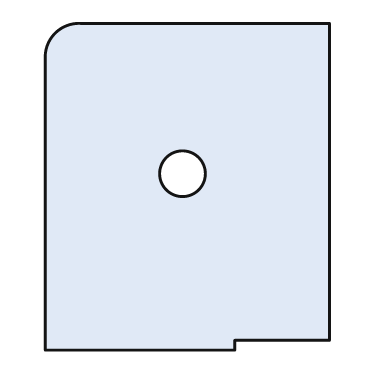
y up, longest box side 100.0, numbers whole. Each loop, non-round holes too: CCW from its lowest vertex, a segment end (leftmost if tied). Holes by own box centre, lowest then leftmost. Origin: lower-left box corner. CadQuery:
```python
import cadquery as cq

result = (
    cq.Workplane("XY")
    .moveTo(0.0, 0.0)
    .lineTo(58.0, 0.0)
    .lineTo(58.0, 3.0)
    .lineTo(87.0, 3.0)
    .lineTo(87.0, 100.0)
    .lineTo(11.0, 100.0)
    .threePointArc((3.0, 97.0), (0.0, 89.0))
    .close()
    .moveTo(42.0, 54.0)
    .circle(7.0)
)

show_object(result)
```